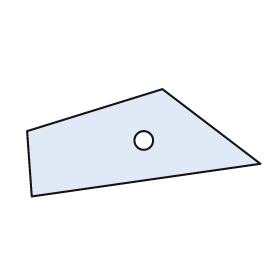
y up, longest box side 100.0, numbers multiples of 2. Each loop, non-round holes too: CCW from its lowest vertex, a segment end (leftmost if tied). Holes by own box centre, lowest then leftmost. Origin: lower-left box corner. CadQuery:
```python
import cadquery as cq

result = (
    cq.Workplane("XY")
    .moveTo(2.0, 0.0)
    .lineTo(100.0, 14.0)
    .lineTo(58.0, 46.0)
    .lineTo(0.0, 28.0)
    .close()
    .moveTo(50.0, 24.0)
    .circle(4.0)
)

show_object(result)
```